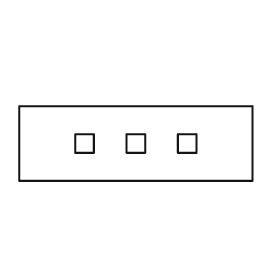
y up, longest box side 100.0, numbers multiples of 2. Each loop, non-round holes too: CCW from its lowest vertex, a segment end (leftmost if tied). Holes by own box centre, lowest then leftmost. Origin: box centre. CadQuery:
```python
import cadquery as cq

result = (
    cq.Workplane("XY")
    .moveTo(-50.0, -16.0)
    .lineTo(50.0, -16.0)
    .lineTo(50.0, 16.0)
    .lineTo(-50.0, 16.0)
    .close()
    .moveTo(-26.0, -4.0)
    .lineTo(-18.0, -4.0)
    .lineTo(-18.0, 4.0)
    .lineTo(-26.0, 4.0)
    .close()
    .moveTo(-4.0, -4.0)
    .lineTo(4.0, -4.0)
    .lineTo(4.0, 4.0)
    .lineTo(-4.0, 4.0)
    .close()
    .moveTo(18.0, -4.0)
    .lineTo(26.0, -4.0)
    .lineTo(26.0, 4.0)
    .lineTo(18.0, 4.0)
    .close()
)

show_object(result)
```